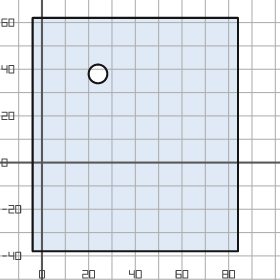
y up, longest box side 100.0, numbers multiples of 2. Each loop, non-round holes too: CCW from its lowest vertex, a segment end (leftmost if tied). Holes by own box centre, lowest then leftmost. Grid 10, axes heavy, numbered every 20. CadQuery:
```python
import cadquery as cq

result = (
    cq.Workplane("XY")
    .moveTo(-4.0, -38.0)
    .lineTo(84.0, -38.0)
    .lineTo(84.0, 62.0)
    .lineTo(-4.0, 62.0)
    .close()
    .moveTo(24.0, 38.0)
    .circle(4.0)
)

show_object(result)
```